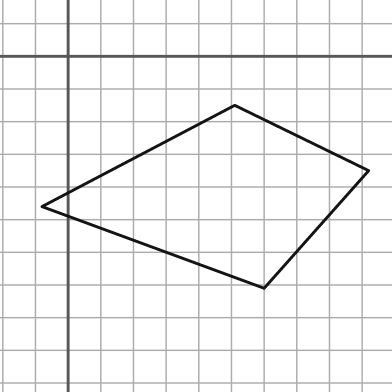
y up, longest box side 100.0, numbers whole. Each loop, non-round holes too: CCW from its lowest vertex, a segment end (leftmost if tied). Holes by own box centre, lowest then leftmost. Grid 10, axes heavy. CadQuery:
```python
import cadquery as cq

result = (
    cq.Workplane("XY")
    .moveTo(60.0, -71.0)
    .lineTo(92.0, -35.0)
    .lineTo(51.0, -15.0)
    .lineTo(-8.0, -46.0)
    .close()
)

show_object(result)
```